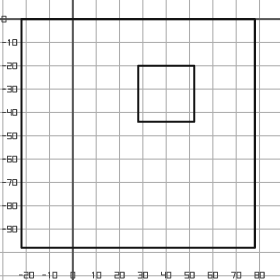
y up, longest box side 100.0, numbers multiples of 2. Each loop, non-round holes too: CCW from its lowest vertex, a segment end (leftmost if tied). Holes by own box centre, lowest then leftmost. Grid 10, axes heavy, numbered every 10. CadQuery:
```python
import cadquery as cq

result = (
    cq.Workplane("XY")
    .moveTo(-22.0, -98.0)
    .lineTo(78.0, -98.0)
    .lineTo(78.0, 0.0)
    .lineTo(-22.0, 0.0)
    .close()
    .moveTo(28.0, -44.0)
    .lineTo(52.0, -44.0)
    .lineTo(52.0, -20.0)
    .lineTo(28.0, -20.0)
    .close()
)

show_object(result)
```